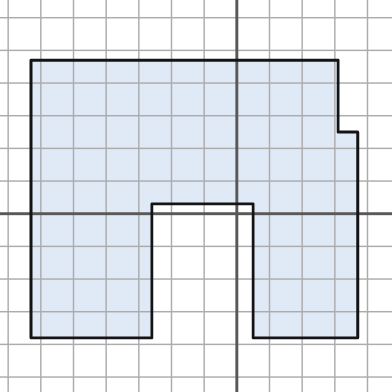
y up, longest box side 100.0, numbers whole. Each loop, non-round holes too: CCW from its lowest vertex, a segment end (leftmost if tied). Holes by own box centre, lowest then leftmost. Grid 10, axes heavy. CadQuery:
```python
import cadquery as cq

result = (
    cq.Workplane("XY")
    .moveTo(-63.0, -38.0)
    .lineTo(-26.0, -38.0)
    .lineTo(-26.0, 3.0)
    .lineTo(5.0, 3.0)
    .lineTo(5.0, -38.0)
    .lineTo(37.0, -38.0)
    .lineTo(37.0, 25.0)
    .lineTo(31.0, 25.0)
    .lineTo(31.0, 47.0)
    .lineTo(-63.0, 47.0)
    .close()
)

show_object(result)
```